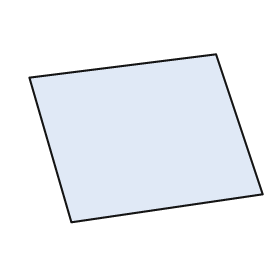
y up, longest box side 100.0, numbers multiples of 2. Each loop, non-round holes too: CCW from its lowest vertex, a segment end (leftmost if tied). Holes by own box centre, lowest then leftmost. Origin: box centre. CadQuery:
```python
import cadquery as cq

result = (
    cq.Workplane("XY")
    .moveTo(-32.0, -36.0)
    .lineTo(50.0, -24.0)
    .lineTo(30.0, 36.0)
    .lineTo(-50.0, 26.0)
    .close()
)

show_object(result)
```